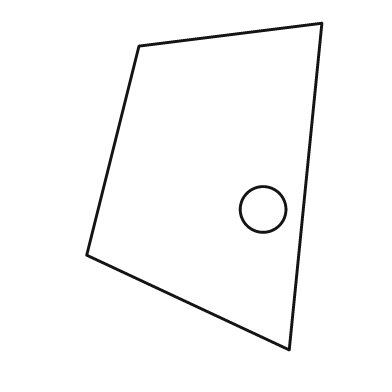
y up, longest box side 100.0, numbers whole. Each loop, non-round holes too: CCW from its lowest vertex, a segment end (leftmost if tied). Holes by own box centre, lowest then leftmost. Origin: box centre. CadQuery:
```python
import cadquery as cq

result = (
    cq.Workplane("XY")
    .moveTo(26.0, -50.0)
    .lineTo(36.0, 50.0)
    .lineTo(-20.0, 43.0)
    .lineTo(-36.0, -21.0)
    .close()
    .moveTo(18.0, -7.0)
    .circle(7.0)
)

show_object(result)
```